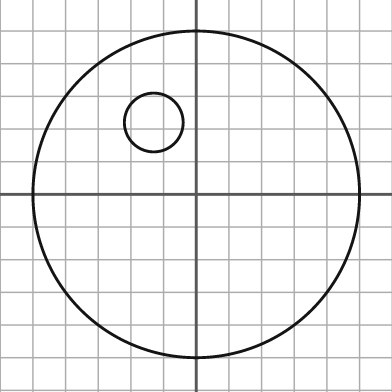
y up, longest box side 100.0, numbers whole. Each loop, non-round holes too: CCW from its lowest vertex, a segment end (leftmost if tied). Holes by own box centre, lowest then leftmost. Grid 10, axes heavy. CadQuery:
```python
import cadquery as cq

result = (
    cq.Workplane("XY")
    .moveTo(0.0, 0.0)
    .circle(50.0)
    .moveTo(-13.0, 22.0)
    .circle(9.0)
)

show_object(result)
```